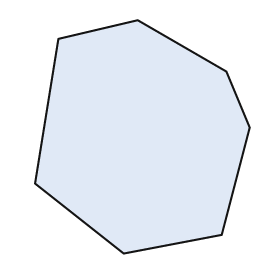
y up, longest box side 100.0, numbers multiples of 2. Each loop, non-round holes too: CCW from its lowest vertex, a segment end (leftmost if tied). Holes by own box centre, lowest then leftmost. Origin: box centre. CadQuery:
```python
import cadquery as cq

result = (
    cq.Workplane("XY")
    .moveTo(-8.0, -50.0)
    .lineTo(34.0, -42.0)
    .lineTo(46.0, 4.0)
    .lineTo(36.0, 28.0)
    .lineTo(-2.0, 50.0)
    .lineTo(-36.0, 42.0)
    .lineTo(-46.0, -20.0)
    .close()
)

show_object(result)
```